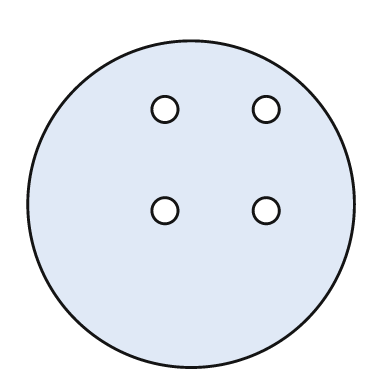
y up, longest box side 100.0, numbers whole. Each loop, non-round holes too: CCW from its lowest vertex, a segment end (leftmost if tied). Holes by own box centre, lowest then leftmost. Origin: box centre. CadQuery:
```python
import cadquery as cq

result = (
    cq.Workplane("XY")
    .moveTo(0.0, 0.0)
    .circle(50.0)
    .moveTo(-8.0, -2.0)
    .circle(4.0)
    .moveTo(23.0, -2.0)
    .circle(4.0)
    .moveTo(-8.0, 29.0)
    .circle(4.0)
    .moveTo(23.0, 29.0)
    .circle(4.0)
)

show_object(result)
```